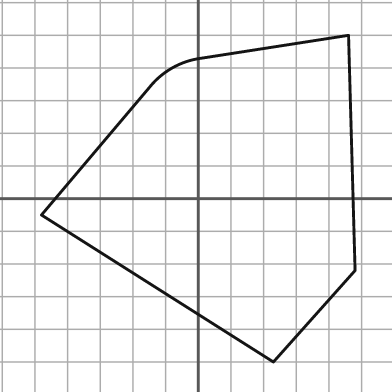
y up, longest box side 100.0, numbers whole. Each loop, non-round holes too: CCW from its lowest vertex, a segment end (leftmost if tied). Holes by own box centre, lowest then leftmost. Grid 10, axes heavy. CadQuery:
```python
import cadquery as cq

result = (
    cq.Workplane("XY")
    .moveTo(23.0, -50.0)
    .lineTo(48.0, -22.0)
    .lineTo(46.0, 50.0)
    .lineTo(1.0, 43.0)
    .threePointArc((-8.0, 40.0), (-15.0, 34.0))
    .lineTo(-48.0, -5.0)
    .close()
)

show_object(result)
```